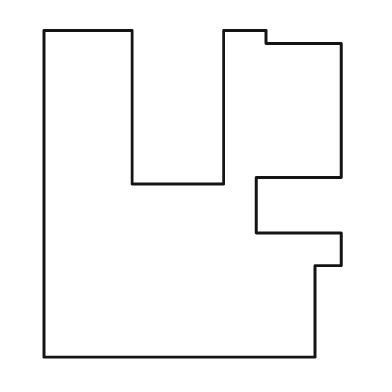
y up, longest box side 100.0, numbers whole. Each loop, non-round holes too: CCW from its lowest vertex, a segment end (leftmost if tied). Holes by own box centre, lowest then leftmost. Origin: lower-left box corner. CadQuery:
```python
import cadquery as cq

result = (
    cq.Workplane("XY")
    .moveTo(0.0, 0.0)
    .lineTo(83.0, 0.0)
    .lineTo(83.0, 28.0)
    .lineTo(91.0, 28.0)
    .lineTo(91.0, 38.0)
    .lineTo(65.0, 38.0)
    .lineTo(65.0, 55.0)
    .lineTo(91.0, 55.0)
    .lineTo(91.0, 96.0)
    .lineTo(68.0, 96.0)
    .lineTo(68.0, 100.0)
    .lineTo(55.0, 100.0)
    .lineTo(55.0, 53.0)
    .lineTo(27.0, 53.0)
    .lineTo(27.0, 100.0)
    .lineTo(0.0, 100.0)
    .close()
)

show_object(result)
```